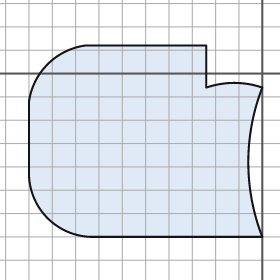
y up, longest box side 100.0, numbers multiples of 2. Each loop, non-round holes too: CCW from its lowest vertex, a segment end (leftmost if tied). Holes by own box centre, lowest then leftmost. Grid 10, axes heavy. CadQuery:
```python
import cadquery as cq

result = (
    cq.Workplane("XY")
    .moveTo(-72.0, -70.0)
    .lineTo(0.0, -70.0)
    .threePointArc((-6.0, -38.0), (0.0, -6.0))
    .threePointArc((-12.0, -4.0), (-24.0, -6.0))
    .lineTo(-24.0, 12.0)
    .lineTo(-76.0, 12.0)
    .threePointArc((-92.0, 4.0), (-100.0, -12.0))
    .lineTo(-100.0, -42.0)
    .threePointArc((-92.0, -62.0), (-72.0, -70.0))
    .close()
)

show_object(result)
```